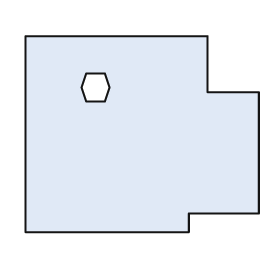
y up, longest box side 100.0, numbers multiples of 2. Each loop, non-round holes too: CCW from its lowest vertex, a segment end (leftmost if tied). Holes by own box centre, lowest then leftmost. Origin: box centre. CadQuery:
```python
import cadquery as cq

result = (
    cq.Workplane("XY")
    .moveTo(-50.0, -42.0)
    .lineTo(20.0, -42.0)
    .lineTo(20.0, -34.0)
    .lineTo(50.0, -34.0)
    .lineTo(50.0, 18.0)
    .lineTo(28.0, 18.0)
    .lineTo(28.0, 42.0)
    .lineTo(-50.0, 42.0)
    .close()
    .moveTo(-24.0, 14.0)
    .lineTo(-16.0, 14.0)
    .lineTo(-14.0, 20.0)
    .lineTo(-16.0, 26.0)
    .lineTo(-24.0, 26.0)
    .lineTo(-26.0, 20.0)
    .close()
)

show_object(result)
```